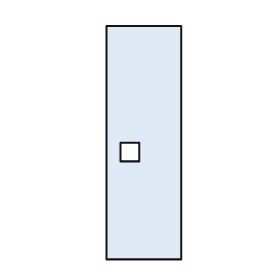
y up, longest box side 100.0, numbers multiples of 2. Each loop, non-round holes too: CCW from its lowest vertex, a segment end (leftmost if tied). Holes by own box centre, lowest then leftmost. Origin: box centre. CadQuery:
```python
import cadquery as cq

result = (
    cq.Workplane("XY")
    .moveTo(-16.0, -50.0)
    .lineTo(16.0, -50.0)
    .lineTo(16.0, 50.0)
    .lineTo(-16.0, 50.0)
    .close()
    .moveTo(-10.0, -8.0)
    .lineTo(-2.0, -8.0)
    .lineTo(-2.0, 0.0)
    .lineTo(-10.0, 0.0)
    .close()
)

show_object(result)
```